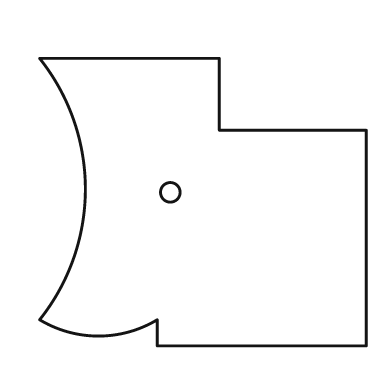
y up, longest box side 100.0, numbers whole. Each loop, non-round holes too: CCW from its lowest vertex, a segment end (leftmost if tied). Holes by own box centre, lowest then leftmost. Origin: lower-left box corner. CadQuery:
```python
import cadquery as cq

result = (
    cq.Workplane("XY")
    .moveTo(36.0, 0.0)
    .lineTo(100.0, 0.0)
    .lineTo(100.0, 66.0)
    .lineTo(55.0, 66.0)
    .lineTo(55.0, 88.0)
    .lineTo(0.0, 88.0)
    .threePointArc((14.0, 48.0), (0.0, 8.0))
    .threePointArc((18.0, 3.0), (36.0, 8.0))
    .close()
    .moveTo(40.0, 47.0)
    .circle(3.0)
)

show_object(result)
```